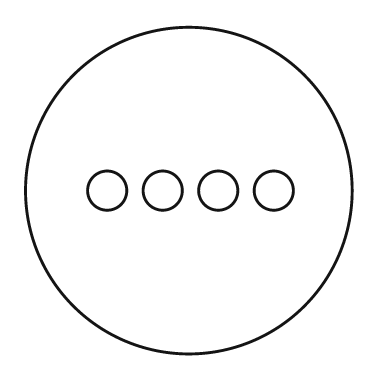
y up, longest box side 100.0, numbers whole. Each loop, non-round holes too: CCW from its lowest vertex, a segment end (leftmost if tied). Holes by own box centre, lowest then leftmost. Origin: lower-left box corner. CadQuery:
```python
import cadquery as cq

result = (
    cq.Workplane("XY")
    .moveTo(50.0, 50.0)
    .circle(50.0)
    .moveTo(25.0, 50.0)
    .circle(6.0)
    .moveTo(42.0, 50.0)
    .circle(6.0)
    .moveTo(59.0, 50.0)
    .circle(6.0)
    .moveTo(76.0, 50.0)
    .circle(6.0)
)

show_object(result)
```